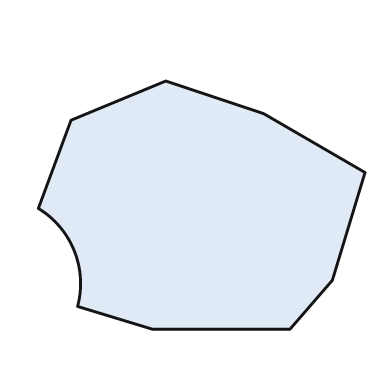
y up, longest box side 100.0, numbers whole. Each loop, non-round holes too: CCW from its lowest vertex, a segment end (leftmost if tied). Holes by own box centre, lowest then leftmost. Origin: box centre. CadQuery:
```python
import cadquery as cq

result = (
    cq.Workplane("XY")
    .moveTo(-15.0, -38.0)
    .lineTo(27.0, -38.0)
    .lineTo(40.0, -23.0)
    .lineTo(50.0, 10.0)
    .lineTo(19.0, 28.0)
    .lineTo(-11.0, 38.0)
    .lineTo(-40.0, 26.0)
    .lineTo(-50.0, -1.0)
    .threePointArc((-39.0, -14.0), (-38.0, -31.0))
    .close()
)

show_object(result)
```